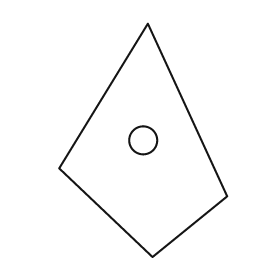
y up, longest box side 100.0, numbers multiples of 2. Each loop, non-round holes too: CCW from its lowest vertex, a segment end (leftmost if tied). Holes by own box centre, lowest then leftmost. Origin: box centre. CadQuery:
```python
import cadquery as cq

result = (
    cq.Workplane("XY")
    .moveTo(4.0, -50.0)
    .lineTo(36.0, -24.0)
    .lineTo(2.0, 50.0)
    .lineTo(-36.0, -12.0)
    .close()
    .moveTo(0.0, 0.0)
    .circle(6.0)
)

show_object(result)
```